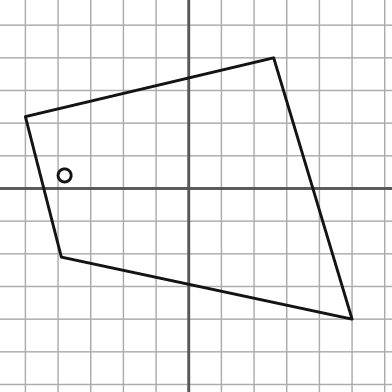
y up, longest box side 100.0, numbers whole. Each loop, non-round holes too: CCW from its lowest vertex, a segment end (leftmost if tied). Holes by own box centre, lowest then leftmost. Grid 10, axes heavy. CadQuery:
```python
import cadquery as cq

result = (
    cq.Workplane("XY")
    .moveTo(50.0, -40.0)
    .lineTo(26.0, 40.0)
    .lineTo(-50.0, 22.0)
    .lineTo(-39.0, -21.0)
    .close()
    .moveTo(-38.0, 4.0)
    .circle(2.0)
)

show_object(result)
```